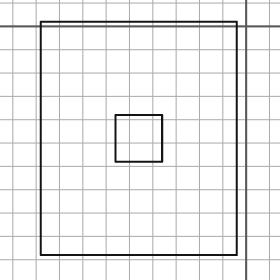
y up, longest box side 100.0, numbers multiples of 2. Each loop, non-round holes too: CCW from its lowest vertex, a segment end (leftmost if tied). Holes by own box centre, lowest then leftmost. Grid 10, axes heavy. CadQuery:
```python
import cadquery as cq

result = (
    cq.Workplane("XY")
    .moveTo(-88.0, -98.0)
    .lineTo(-4.0, -98.0)
    .lineTo(-4.0, 2.0)
    .lineTo(-88.0, 2.0)
    .close()
    .moveTo(-56.0, -58.0)
    .lineTo(-36.0, -58.0)
    .lineTo(-36.0, -38.0)
    .lineTo(-56.0, -38.0)
    .close()
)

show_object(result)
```